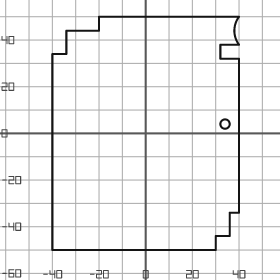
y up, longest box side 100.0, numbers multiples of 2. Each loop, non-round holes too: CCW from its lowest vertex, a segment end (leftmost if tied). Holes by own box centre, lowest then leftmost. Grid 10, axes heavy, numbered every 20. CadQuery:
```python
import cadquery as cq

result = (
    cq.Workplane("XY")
    .moveTo(-40.0, -50.0)
    .lineTo(30.0, -50.0)
    .lineTo(30.0, -44.0)
    .lineTo(36.0, -44.0)
    .lineTo(36.0, -34.0)
    .lineTo(40.0, -34.0)
    .lineTo(40.0, 32.0)
    .lineTo(32.0, 32.0)
    .lineTo(32.0, 38.0)
    .lineTo(40.0, 38.0)
    .threePointArc((38.0, 44.0), (40.0, 50.0))
    .lineTo(-20.0, 50.0)
    .lineTo(-20.0, 44.0)
    .lineTo(-34.0, 44.0)
    .lineTo(-34.0, 34.0)
    .lineTo(-40.0, 34.0)
    .close()
    .moveTo(34.0, 4.0)
    .circle(2.0)
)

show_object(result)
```